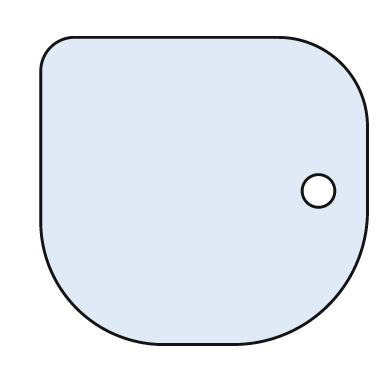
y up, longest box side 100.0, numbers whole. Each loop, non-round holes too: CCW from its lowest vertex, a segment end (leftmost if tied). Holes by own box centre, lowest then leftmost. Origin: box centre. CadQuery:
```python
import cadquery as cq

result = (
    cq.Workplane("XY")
    .moveTo(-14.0, -47.0)
    .lineTo(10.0, -47.0)
    .threePointArc((38.0, -35.0), (50.0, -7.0))
    .lineTo(50.0, 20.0)
    .threePointArc((42.0, 39.0), (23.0, 47.0))
    .lineTo(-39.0, 47.0)
    .threePointArc((-47.0, 44.0), (-50.0, 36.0))
    .lineTo(-50.0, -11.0)
    .threePointArc((-39.0, -36.0), (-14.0, -47.0))
    .close()
    .moveTo(35.0, 0.0)
    .circle(5.0)
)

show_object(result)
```